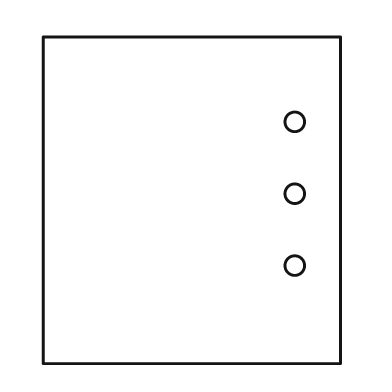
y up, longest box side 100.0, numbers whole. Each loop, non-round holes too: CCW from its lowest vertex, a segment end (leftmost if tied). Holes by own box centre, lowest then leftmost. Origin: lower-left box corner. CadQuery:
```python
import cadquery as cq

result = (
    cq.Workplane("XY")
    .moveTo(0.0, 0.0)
    .lineTo(91.0, 0.0)
    .lineTo(91.0, 100.0)
    .lineTo(0.0, 100.0)
    .close()
    .moveTo(77.0, 30.0)
    .circle(3.0)
    .moveTo(77.0, 52.0)
    .circle(3.0)
    .moveTo(77.0, 74.0)
    .circle(3.0)
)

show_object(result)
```